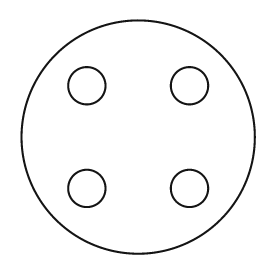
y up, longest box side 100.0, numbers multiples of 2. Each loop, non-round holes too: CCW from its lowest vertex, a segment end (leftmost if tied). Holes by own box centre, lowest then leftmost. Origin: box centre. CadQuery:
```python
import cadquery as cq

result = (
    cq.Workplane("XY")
    .moveTo(0.0, 0.0)
    .circle(50.0)
    .moveTo(-22.0, -22.0)
    .circle(8.0)
    .moveTo(22.0, -22.0)
    .circle(8.0)
    .moveTo(-22.0, 22.0)
    .circle(8.0)
    .moveTo(22.0, 22.0)
    .circle(8.0)
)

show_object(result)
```